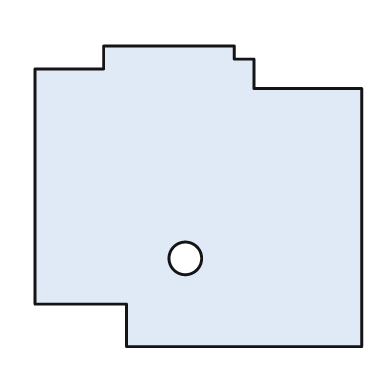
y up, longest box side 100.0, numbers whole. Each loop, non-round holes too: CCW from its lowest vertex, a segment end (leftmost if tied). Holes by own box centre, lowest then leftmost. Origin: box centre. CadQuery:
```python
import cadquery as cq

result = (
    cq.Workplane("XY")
    .moveTo(-22.0, -46.0)
    .lineTo(50.0, -46.0)
    .lineTo(50.0, 33.0)
    .lineTo(17.0, 33.0)
    .lineTo(17.0, 42.0)
    .lineTo(11.0, 42.0)
    .lineTo(11.0, 46.0)
    .lineTo(-29.0, 46.0)
    .lineTo(-29.0, 39.0)
    .lineTo(-50.0, 39.0)
    .lineTo(-50.0, -33.0)
    .lineTo(-22.0, -33.0)
    .close()
    .moveTo(-4.0, -19.0)
    .circle(5.0)
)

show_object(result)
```